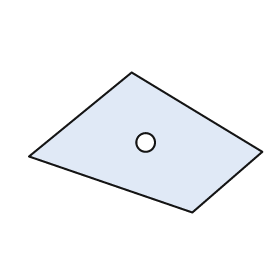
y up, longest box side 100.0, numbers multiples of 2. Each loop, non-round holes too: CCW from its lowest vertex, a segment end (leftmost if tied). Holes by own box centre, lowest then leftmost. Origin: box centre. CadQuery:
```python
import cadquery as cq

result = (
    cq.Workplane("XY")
    .moveTo(20.0, -30.0)
    .lineTo(50.0, -4.0)
    .lineTo(-6.0, 30.0)
    .lineTo(-50.0, -6.0)
    .close()
    .moveTo(0.0, 0.0)
    .circle(4.0)
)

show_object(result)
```